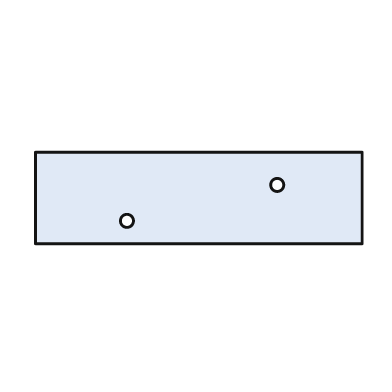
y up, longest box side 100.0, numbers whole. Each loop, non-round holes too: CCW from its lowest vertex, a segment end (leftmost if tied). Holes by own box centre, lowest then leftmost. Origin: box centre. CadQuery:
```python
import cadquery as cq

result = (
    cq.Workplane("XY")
    .moveTo(-50.0, -14.0)
    .lineTo(50.0, -14.0)
    .lineTo(50.0, 14.0)
    .lineTo(-50.0, 14.0)
    .close()
    .moveTo(-22.0, -7.0)
    .circle(2.0)
    .moveTo(24.0, 4.0)
    .circle(2.0)
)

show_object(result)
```